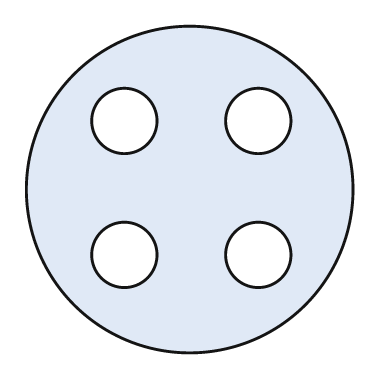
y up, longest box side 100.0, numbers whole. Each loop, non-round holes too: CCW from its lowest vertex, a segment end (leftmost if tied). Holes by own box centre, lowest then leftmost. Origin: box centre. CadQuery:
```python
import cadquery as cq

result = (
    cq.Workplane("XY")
    .moveTo(0.0, 0.0)
    .circle(50.0)
    .moveTo(-20.0, -20.0)
    .circle(10.0)
    .moveTo(21.0, -20.0)
    .circle(10.0)
    .moveTo(-20.0, 21.0)
    .circle(10.0)
    .moveTo(21.0, 21.0)
    .circle(10.0)
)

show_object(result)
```